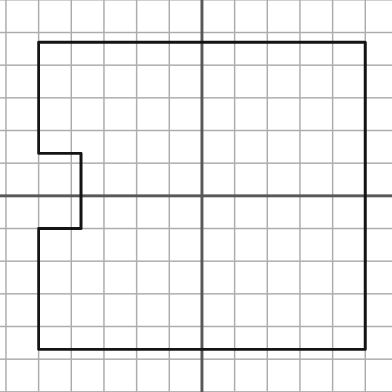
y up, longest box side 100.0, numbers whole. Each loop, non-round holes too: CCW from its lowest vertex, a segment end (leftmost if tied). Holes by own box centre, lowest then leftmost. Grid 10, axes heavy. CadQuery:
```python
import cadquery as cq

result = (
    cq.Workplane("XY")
    .moveTo(-50.0, -47.0)
    .lineTo(50.0, -47.0)
    .lineTo(50.0, 47.0)
    .lineTo(-50.0, 47.0)
    .lineTo(-50.0, 13.0)
    .lineTo(-37.0, 13.0)
    .lineTo(-37.0, -10.0)
    .lineTo(-50.0, -10.0)
    .close()
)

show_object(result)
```